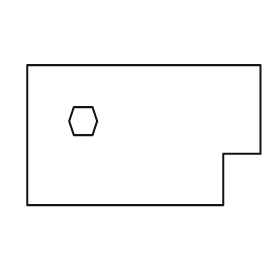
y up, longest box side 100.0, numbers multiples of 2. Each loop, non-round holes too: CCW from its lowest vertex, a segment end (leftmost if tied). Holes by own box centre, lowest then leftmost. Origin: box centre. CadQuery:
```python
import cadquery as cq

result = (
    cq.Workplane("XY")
    .moveTo(-50.0, -30.0)
    .lineTo(34.0, -30.0)
    .lineTo(34.0, -8.0)
    .lineTo(50.0, -8.0)
    .lineTo(50.0, 30.0)
    .lineTo(-50.0, 30.0)
    .close()
    .moveTo(-30.0, 0.0)
    .lineTo(-22.0, 0.0)
    .lineTo(-20.0, 6.0)
    .lineTo(-22.0, 12.0)
    .lineTo(-30.0, 12.0)
    .lineTo(-32.0, 6.0)
    .close()
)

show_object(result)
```